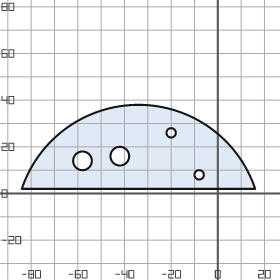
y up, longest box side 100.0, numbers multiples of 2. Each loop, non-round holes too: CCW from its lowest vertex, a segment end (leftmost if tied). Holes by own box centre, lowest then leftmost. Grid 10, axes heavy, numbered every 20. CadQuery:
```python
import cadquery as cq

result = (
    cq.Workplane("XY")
    .moveTo(-84.0, 2.0)
    .lineTo(16.0, 2.0)
    .threePointArc((-34.0, 38.0), (-84.0, 2.0))
    .close()
    .moveTo(-8.0, 8.0)
    .circle(2.0)
    .moveTo(-58.0, 14.0)
    .circle(4.0)
    .moveTo(-42.0, 16.0)
    .circle(4.0)
    .moveTo(-20.0, 26.0)
    .circle(2.0)
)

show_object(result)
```